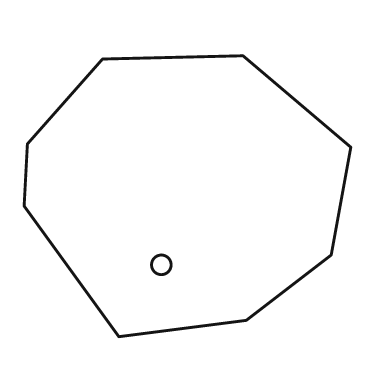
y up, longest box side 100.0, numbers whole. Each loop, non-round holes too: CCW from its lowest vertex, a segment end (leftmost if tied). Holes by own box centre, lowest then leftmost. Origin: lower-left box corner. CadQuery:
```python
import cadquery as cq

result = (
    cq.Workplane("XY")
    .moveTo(29.0, 0.0)
    .lineTo(68.0, 5.0)
    .lineTo(94.0, 25.0)
    .lineTo(100.0, 58.0)
    .lineTo(67.0, 86.0)
    .lineTo(24.0, 85.0)
    .lineTo(1.0, 59.0)
    .lineTo(0.0, 40.0)
    .close()
    .moveTo(42.0, 22.0)
    .circle(3.0)
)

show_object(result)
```